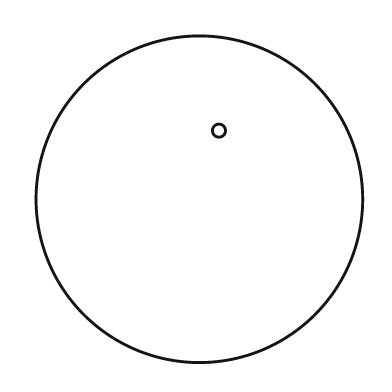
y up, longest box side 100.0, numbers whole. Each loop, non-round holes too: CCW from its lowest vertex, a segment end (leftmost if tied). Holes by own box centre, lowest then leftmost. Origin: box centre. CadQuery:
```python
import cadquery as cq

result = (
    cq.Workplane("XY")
    .moveTo(0.0, 0.0)
    .circle(50.0)
    .moveTo(6.0, 21.0)
    .circle(2.0)
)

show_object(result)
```